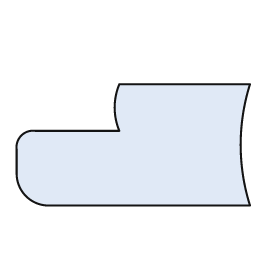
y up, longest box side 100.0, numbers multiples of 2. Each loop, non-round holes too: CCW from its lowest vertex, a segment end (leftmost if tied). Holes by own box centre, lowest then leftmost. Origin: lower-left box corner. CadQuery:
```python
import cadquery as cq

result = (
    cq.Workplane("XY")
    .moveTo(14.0, 0.0)
    .lineTo(100.0, 0.0)
    .threePointArc((96.0, 26.0), (100.0, 52.0))
    .lineTo(44.0, 52.0)
    .threePointArc((42.0, 42.0), (44.0, 32.0))
    .lineTo(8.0, 32.0)
    .threePointArc((2.0, 30.0), (0.0, 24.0))
    .lineTo(0.0, 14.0)
    .threePointArc((4.0, 4.0), (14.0, 0.0))
    .close()
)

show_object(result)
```